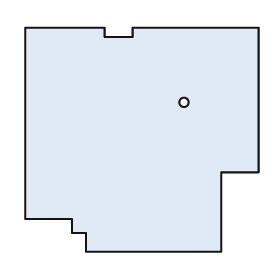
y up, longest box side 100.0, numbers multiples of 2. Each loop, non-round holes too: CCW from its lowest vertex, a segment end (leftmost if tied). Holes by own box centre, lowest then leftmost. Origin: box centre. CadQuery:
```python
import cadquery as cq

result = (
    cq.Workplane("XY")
    .moveTo(-24.0, -48.0)
    .lineTo(34.0, -48.0)
    .lineTo(34.0, -14.0)
    .lineTo(50.0, -14.0)
    .lineTo(50.0, 48.0)
    .lineTo(-4.0, 48.0)
    .lineTo(-4.0, 44.0)
    .lineTo(-16.0, 44.0)
    .lineTo(-16.0, 48.0)
    .lineTo(-50.0, 48.0)
    .lineTo(-50.0, -34.0)
    .lineTo(-30.0, -34.0)
    .lineTo(-30.0, -40.0)
    .lineTo(-24.0, -40.0)
    .close()
    .moveTo(18.0, 16.0)
    .circle(2.0)
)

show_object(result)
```